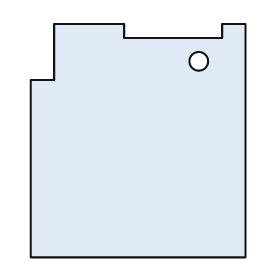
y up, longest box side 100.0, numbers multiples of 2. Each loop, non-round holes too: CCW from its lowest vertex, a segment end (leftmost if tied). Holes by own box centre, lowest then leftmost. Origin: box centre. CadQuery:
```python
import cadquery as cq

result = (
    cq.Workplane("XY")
    .moveTo(-46.0, -50.0)
    .lineTo(46.0, -50.0)
    .lineTo(46.0, 50.0)
    .lineTo(36.0, 50.0)
    .lineTo(36.0, 44.0)
    .lineTo(-6.0, 44.0)
    .lineTo(-6.0, 50.0)
    .lineTo(-36.0, 50.0)
    .lineTo(-36.0, 26.0)
    .lineTo(-46.0, 26.0)
    .close()
    .moveTo(26.0, 34.0)
    .circle(4.0)
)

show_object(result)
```